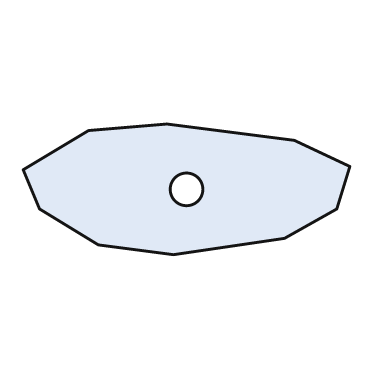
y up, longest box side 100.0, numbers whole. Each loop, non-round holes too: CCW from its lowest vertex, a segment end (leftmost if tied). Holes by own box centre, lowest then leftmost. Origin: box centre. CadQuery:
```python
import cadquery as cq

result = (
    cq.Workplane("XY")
    .moveTo(-4.0, -20.0)
    .lineTo(30.0, -15.0)
    .lineTo(46.0, -6.0)
    .lineTo(50.0, 7.0)
    .lineTo(33.0, 15.0)
    .lineTo(-6.0, 20.0)
    .lineTo(-30.0, 18.0)
    .lineTo(-50.0, 6.0)
    .lineTo(-45.0, -6.0)
    .lineTo(-27.0, -17.0)
    .close()
    .moveTo(0.0, 0.0)
    .circle(5.0)
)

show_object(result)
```